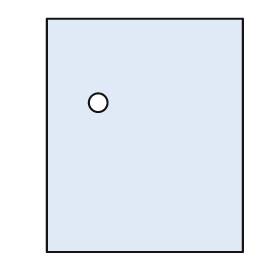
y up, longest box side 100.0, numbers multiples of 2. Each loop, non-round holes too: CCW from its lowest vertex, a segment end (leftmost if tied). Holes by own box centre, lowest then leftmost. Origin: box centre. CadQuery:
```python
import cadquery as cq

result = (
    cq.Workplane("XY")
    .moveTo(-42.0, -50.0)
    .lineTo(42.0, -50.0)
    .lineTo(42.0, 50.0)
    .lineTo(-42.0, 50.0)
    .close()
    .moveTo(-20.0, 14.0)
    .circle(4.0)
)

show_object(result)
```